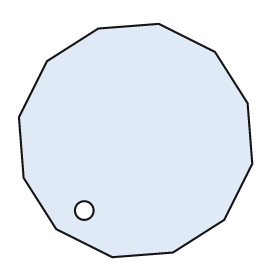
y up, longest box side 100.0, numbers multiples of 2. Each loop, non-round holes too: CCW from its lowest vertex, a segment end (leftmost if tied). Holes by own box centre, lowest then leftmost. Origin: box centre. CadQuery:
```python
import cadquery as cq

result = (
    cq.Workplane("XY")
    .moveTo(-10.0, -50.0)
    .lineTo(16.0, -48.0)
    .lineTo(38.0, -34.0)
    .lineTo(50.0, -10.0)
    .lineTo(48.0, 16.0)
    .lineTo(34.0, 38.0)
    .lineTo(10.0, 50.0)
    .lineTo(-16.0, 48.0)
    .lineTo(-38.0, 34.0)
    .lineTo(-50.0, 10.0)
    .lineTo(-48.0, -16.0)
    .lineTo(-34.0, -38.0)
    .close()
    .moveTo(-22.0, -30.0)
    .circle(4.0)
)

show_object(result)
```